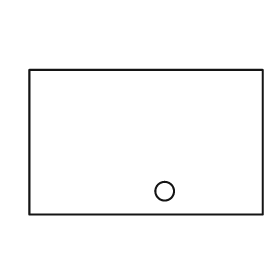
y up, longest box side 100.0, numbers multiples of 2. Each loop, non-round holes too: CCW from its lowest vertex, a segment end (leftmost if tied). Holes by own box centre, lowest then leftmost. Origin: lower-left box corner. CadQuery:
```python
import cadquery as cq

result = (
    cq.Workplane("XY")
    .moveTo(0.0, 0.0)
    .lineTo(100.0, 0.0)
    .lineTo(100.0, 62.0)
    .lineTo(0.0, 62.0)
    .close()
    .moveTo(58.0, 10.0)
    .circle(4.0)
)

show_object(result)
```